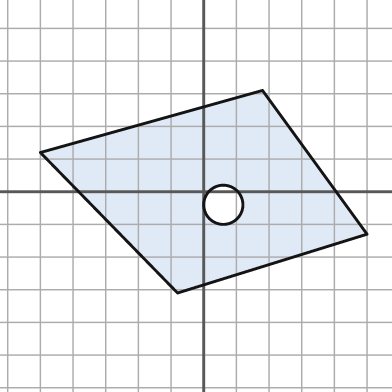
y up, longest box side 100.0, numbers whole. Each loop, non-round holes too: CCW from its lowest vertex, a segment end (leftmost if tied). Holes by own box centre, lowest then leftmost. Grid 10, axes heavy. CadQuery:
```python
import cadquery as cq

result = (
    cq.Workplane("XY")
    .moveTo(-8.0, -31.0)
    .lineTo(50.0, -13.0)
    .lineTo(18.0, 31.0)
    .lineTo(-50.0, 12.0)
    .close()
    .moveTo(6.0, -4.0)
    .circle(6.0)
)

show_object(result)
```